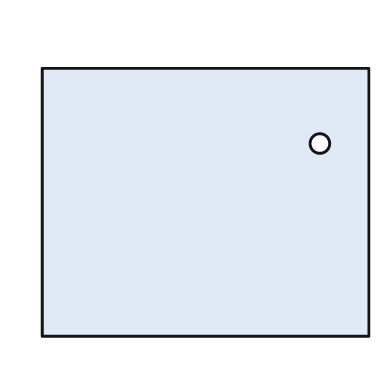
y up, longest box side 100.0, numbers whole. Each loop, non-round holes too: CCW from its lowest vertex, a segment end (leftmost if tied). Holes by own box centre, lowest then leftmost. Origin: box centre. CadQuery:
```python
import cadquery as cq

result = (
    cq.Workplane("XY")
    .moveTo(-50.0, -41.0)
    .lineTo(50.0, -41.0)
    .lineTo(50.0, 41.0)
    .lineTo(-50.0, 41.0)
    .close()
    .moveTo(35.0, 18.0)
    .circle(3.0)
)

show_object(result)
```